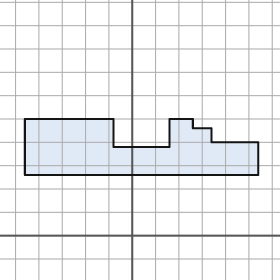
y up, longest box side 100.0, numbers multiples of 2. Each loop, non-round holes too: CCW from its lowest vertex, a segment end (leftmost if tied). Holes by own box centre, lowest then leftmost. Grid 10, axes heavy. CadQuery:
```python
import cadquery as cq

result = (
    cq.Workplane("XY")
    .moveTo(-46.0, 26.0)
    .lineTo(54.0, 26.0)
    .lineTo(54.0, 40.0)
    .lineTo(34.0, 40.0)
    .lineTo(34.0, 46.0)
    .lineTo(26.0, 46.0)
    .lineTo(26.0, 50.0)
    .lineTo(16.0, 50.0)
    .lineTo(16.0, 38.0)
    .lineTo(-8.0, 38.0)
    .lineTo(-8.0, 50.0)
    .lineTo(-46.0, 50.0)
    .close()
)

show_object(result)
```